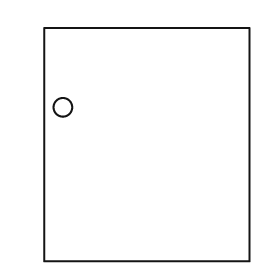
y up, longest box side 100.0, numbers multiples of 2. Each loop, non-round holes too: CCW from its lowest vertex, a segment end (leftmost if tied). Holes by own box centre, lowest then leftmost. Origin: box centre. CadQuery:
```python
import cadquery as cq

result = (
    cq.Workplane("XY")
    .moveTo(-44.0, -50.0)
    .lineTo(44.0, -50.0)
    .lineTo(44.0, 50.0)
    .lineTo(-44.0, 50.0)
    .close()
    .moveTo(-36.0, 16.0)
    .circle(4.0)
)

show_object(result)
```